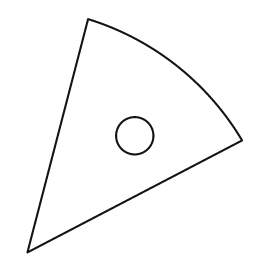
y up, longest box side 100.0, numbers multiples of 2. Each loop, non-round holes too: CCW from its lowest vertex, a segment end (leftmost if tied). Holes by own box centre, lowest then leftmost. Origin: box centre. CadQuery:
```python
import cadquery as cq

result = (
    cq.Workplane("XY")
    .moveTo(-46.0, -50.0)
    .lineTo(46.0, -2.0)
    .threePointArc((18.0, 30.0), (-20.0, 50.0))
    .close()
    .moveTo(0.0, 0.0)
    .circle(8.0)
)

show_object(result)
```